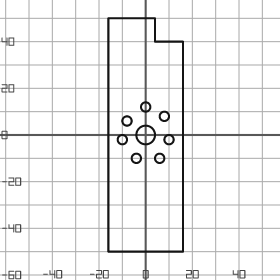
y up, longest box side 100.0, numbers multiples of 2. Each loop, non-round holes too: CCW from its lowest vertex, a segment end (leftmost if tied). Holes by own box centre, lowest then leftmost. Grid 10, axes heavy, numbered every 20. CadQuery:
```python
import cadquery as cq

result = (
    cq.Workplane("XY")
    .moveTo(-16.0, -50.0)
    .lineTo(16.0, -50.0)
    .lineTo(16.0, 40.0)
    .lineTo(4.0, 40.0)
    .lineTo(4.0, 50.0)
    .lineTo(-16.0, 50.0)
    .close()
    .moveTo(-4.0, -10.0)
    .circle(2.0)
    .moveTo(6.0, -10.0)
    .circle(2.0)
    .moveTo(-10.0, -2.0)
    .circle(2.0)
    .moveTo(10.0, -2.0)
    .circle(2.0)
    .moveTo(0.0, 0.0)
    .circle(4.0)
    .moveTo(-8.0, 6.0)
    .circle(2.0)
    .moveTo(8.0, 8.0)
    .circle(2.0)
    .moveTo(0.0, 12.0)
    .circle(2.0)
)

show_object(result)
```